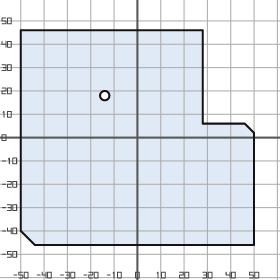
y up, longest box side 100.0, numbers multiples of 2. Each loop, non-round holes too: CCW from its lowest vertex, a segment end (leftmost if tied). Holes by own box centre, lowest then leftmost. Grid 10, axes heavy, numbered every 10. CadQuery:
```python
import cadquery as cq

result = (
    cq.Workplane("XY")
    .moveTo(-44.0, -46.0)
    .lineTo(50.0, -46.0)
    .lineTo(50.0, 2.0)
    .lineTo(46.0, 6.0)
    .lineTo(28.0, 6.0)
    .lineTo(28.0, 46.0)
    .lineTo(-50.0, 46.0)
    .lineTo(-50.0, -40.0)
    .close()
    .moveTo(-14.0, 18.0)
    .circle(2.0)
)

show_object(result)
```